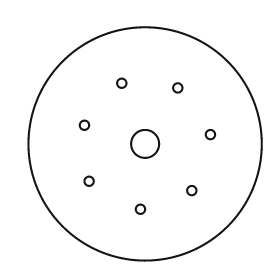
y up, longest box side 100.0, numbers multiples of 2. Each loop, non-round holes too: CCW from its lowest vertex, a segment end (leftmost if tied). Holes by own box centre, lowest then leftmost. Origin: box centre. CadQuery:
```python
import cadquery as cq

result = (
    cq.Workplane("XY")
    .moveTo(0.0, 0.0)
    .circle(50.0)
    .moveTo(-2.0, -28.0)
    .circle(2.0)
    .moveTo(20.0, -20.0)
    .circle(2.0)
    .moveTo(-24.0, -16.0)
    .circle(2.0)
    .moveTo(0.0, 0.0)
    .circle(6.0)
    .moveTo(28.0, 4.0)
    .circle(2.0)
    .moveTo(-26.0, 8.0)
    .circle(2.0)
    .moveTo(14.0, 24.0)
    .circle(2.0)
    .moveTo(-10.0, 26.0)
    .circle(2.0)
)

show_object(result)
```